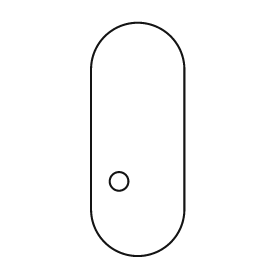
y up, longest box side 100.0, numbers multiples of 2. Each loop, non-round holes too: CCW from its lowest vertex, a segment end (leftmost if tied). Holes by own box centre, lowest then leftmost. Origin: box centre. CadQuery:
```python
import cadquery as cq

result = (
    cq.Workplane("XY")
    .moveTo(-20.0, -30.0)
    .threePointArc((0.0, -50.0), (20.0, -30.0))
    .lineTo(20.0, 30.0)
    .threePointArc((0.0, 50.0), (-20.0, 30.0))
    .close()
    .moveTo(-8.0, -18.0)
    .circle(4.0)
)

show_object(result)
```